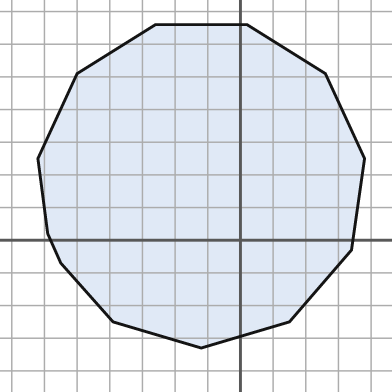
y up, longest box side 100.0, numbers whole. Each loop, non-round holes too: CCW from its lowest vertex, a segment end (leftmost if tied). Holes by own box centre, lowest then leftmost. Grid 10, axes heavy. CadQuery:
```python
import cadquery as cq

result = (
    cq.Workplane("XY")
    .moveTo(-12.0, -33.0)
    .lineTo(15.0, -25.0)
    .lineTo(34.0, -3.0)
    .lineTo(38.0, 25.0)
    .lineTo(26.0, 51.0)
    .lineTo(2.0, 66.0)
    .lineTo(-26.0, 66.0)
    .lineTo(-50.0, 51.0)
    .lineTo(-62.0, 25.0)
    .lineTo(-59.0, 2.0)
    .lineTo(-55.0, -7.0)
    .lineTo(-39.0, -25.0)
    .close()
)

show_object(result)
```